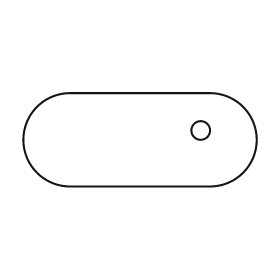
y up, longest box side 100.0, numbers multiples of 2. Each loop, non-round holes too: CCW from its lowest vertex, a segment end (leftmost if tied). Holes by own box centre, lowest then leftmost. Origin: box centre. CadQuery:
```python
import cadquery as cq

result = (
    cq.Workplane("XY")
    .moveTo(-30.0, -20.0)
    .lineTo(30.0, -20.0)
    .threePointArc((50.0, 0.0), (30.0, 20.0))
    .lineTo(-30.0, 20.0)
    .threePointArc((-50.0, 0.0), (-30.0, -20.0))
    .close()
    .moveTo(26.0, 4.0)
    .circle(4.0)
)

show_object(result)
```